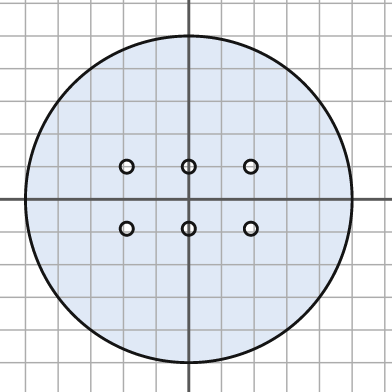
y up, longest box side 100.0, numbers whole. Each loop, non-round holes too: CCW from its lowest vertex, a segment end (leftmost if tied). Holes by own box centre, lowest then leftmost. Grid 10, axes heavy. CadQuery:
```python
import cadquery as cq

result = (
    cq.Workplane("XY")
    .moveTo(0.0, 0.0)
    .circle(50.0)
    .moveTo(-19.0, -9.0)
    .circle(2.0)
    .moveTo(0.0, -9.0)
    .circle(2.0)
    .moveTo(19.0, -9.0)
    .circle(2.0)
    .moveTo(-19.0, 10.0)
    .circle(2.0)
    .moveTo(0.0, 10.0)
    .circle(2.0)
    .moveTo(19.0, 10.0)
    .circle(2.0)
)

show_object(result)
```